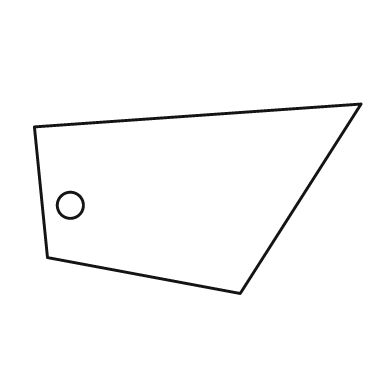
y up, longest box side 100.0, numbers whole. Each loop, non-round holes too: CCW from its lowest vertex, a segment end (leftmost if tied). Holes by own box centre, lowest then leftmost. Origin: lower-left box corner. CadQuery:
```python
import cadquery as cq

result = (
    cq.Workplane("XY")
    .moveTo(63.0, 0.0)
    .lineTo(100.0, 58.0)
    .lineTo(0.0, 51.0)
    .lineTo(4.0, 11.0)
    .close()
    .moveTo(11.0, 27.0)
    .circle(4.0)
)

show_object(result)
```